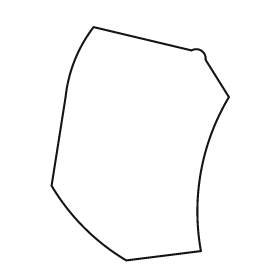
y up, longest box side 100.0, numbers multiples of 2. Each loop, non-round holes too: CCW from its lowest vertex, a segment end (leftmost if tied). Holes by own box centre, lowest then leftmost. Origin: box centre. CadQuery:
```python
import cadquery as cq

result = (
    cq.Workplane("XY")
    .moveTo(-6.0, -50.0)
    .lineTo(26.0, -46.0)
    .threePointArc((26.0, -12.0), (38.0, 20.0))
    .lineTo(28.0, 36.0)
    .threePointArc((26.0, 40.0), (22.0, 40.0))
    .lineTo(-20.0, 50.0)
    .threePointArc((-28.0, 36.0), (-32.0, 20.0))
    .lineTo(-38.0, -18.0)
    .threePointArc((-24.0, -36.0), (-6.0, -50.0))
    .close()
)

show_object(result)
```